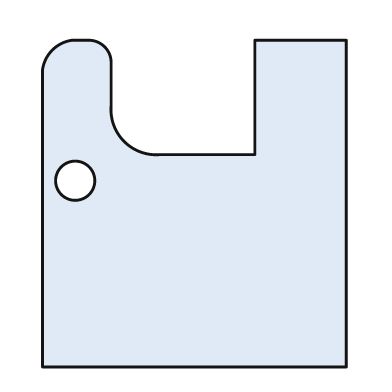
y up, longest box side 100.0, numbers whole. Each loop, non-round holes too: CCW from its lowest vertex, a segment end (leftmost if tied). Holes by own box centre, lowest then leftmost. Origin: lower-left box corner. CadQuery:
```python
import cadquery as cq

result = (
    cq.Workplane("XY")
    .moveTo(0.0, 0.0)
    .lineTo(93.0, 0.0)
    .lineTo(93.0, 100.0)
    .lineTo(65.0, 100.0)
    .lineTo(65.0, 65.0)
    .lineTo(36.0, 65.0)
    .threePointArc((25.0, 69.0), (21.0, 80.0))
    .lineTo(21.0, 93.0)
    .threePointArc((19.0, 98.0), (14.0, 100.0))
    .lineTo(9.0, 100.0)
    .threePointArc((3.0, 97.0), (0.0, 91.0))
    .close()
    .moveTo(10.0, 57.0)
    .circle(6.0)
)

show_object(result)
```